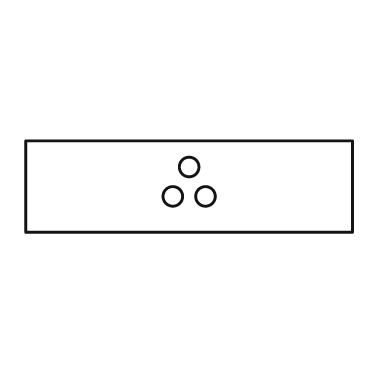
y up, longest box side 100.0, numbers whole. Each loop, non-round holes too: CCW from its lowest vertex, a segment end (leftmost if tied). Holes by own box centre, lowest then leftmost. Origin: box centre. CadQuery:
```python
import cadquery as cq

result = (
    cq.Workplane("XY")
    .moveTo(-50.0, -14.0)
    .lineTo(50.0, -14.0)
    .lineTo(50.0, 14.0)
    .lineTo(-50.0, 14.0)
    .close()
    .moveTo(-5.0, -3.0)
    .circle(3.0)
    .moveTo(5.0, -3.0)
    .circle(3.0)
    .moveTo(0.0, 6.0)
    .circle(3.0)
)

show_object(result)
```